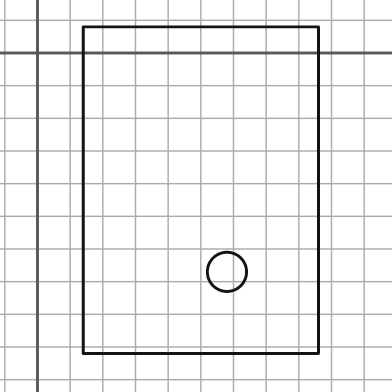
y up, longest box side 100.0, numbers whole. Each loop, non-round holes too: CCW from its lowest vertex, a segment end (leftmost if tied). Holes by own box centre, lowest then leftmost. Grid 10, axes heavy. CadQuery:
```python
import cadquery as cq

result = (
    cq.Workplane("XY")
    .moveTo(14.0, -92.0)
    .lineTo(86.0, -92.0)
    .lineTo(86.0, 8.0)
    .lineTo(14.0, 8.0)
    .close()
    .moveTo(58.0, -67.0)
    .circle(6.0)
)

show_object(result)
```